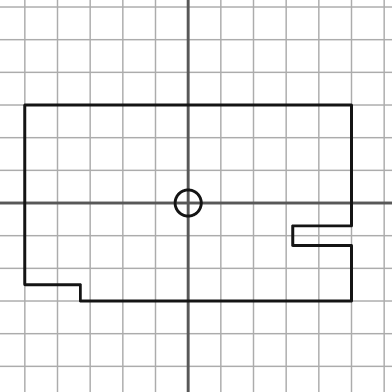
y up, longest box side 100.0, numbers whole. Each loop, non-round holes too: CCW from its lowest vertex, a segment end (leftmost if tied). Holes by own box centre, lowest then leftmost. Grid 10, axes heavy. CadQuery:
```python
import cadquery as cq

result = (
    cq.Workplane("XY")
    .moveTo(-33.0, -30.0)
    .lineTo(50.0, -30.0)
    .lineTo(50.0, -13.0)
    .lineTo(32.0, -13.0)
    .lineTo(32.0, -7.0)
    .lineTo(50.0, -7.0)
    .lineTo(50.0, 30.0)
    .lineTo(-50.0, 30.0)
    .lineTo(-50.0, -25.0)
    .lineTo(-33.0, -25.0)
    .close()
    .moveTo(0.0, 0.0)
    .circle(4.0)
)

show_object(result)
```